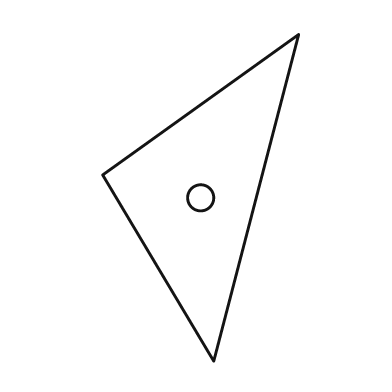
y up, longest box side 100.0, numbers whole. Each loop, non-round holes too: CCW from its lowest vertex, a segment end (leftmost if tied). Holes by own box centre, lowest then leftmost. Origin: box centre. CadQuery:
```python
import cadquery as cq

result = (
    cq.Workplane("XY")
    .moveTo(4.0, -50.0)
    .lineTo(30.0, 50.0)
    .lineTo(-30.0, 7.0)
    .close()
    .moveTo(0.0, 0.0)
    .circle(4.0)
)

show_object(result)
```